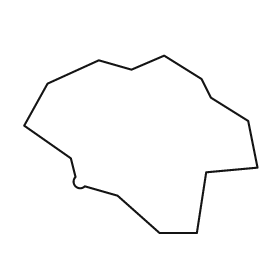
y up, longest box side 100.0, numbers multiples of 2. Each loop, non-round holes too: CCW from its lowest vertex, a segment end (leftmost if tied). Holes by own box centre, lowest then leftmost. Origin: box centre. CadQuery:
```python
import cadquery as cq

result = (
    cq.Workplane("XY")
    .moveTo(8.0, -38.0)
    .lineTo(24.0, -38.0)
    .lineTo(28.0, -12.0)
    .lineTo(50.0, -10.0)
    .lineTo(46.0, 10.0)
    .lineTo(30.0, 20.0)
    .lineTo(26.0, 28.0)
    .lineTo(10.0, 38.0)
    .lineTo(-4.0, 32.0)
    .lineTo(-18.0, 36.0)
    .lineTo(-40.0, 26.0)
    .lineTo(-50.0, 8.0)
    .lineTo(-30.0, -6.0)
    .lineTo(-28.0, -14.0)
    .threePointArc((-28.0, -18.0), (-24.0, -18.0))
    .lineTo(-10.0, -22.0)
    .close()
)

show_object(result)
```